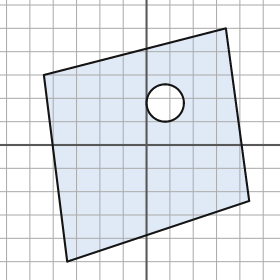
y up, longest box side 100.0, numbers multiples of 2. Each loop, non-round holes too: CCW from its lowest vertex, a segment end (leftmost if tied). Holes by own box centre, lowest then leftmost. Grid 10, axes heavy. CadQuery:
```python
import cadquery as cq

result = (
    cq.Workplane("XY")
    .moveTo(-34.0, -50.0)
    .lineTo(44.0, -24.0)
    .lineTo(34.0, 50.0)
    .lineTo(-44.0, 30.0)
    .close()
    .moveTo(8.0, 18.0)
    .circle(8.0)
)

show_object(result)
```